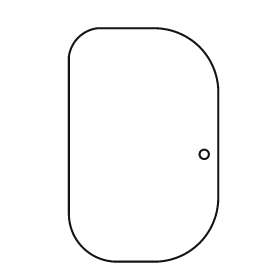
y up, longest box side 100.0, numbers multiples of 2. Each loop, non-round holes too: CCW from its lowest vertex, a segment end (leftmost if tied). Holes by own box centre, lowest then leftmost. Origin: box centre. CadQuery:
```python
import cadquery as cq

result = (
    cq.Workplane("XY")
    .moveTo(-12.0, -50.0)
    .lineTo(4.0, -50.0)
    .threePointArc((24.0, -42.0), (32.0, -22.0))
    .lineTo(32.0, 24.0)
    .threePointArc((24.0, 42.0), (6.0, 50.0))
    .lineTo(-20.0, 50.0)
    .threePointArc((-28.0, 46.0), (-32.0, 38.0))
    .lineTo(-32.0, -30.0)
    .threePointArc((-26.0, -44.0), (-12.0, -50.0))
    .close()
    .moveTo(26.0, -4.0)
    .circle(2.0)
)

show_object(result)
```